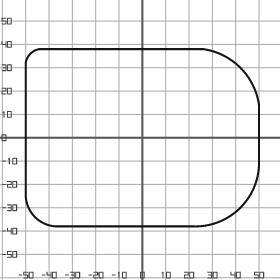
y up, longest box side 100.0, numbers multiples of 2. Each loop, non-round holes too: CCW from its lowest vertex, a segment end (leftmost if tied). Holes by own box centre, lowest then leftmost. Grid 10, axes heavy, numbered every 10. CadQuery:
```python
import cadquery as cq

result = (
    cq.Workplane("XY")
    .moveTo(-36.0, -38.0)
    .lineTo(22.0, -38.0)
    .threePointArc((42.0, -30.0), (50.0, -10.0))
    .lineTo(50.0, 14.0)
    .threePointArc((42.0, 30.0), (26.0, 38.0))
    .lineTo(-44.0, 38.0)
    .threePointArc((-48.0, 36.0), (-50.0, 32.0))
    .lineTo(-50.0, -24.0)
    .threePointArc((-46.0, -34.0), (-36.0, -38.0))
    .close()
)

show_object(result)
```